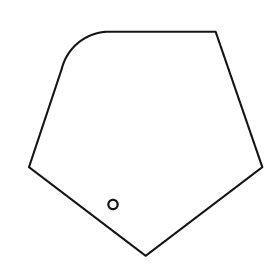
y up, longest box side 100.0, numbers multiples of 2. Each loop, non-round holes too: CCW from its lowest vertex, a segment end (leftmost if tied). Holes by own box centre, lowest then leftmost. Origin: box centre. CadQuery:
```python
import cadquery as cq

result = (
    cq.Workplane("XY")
    .moveTo(0.0, -48.0)
    .lineTo(50.0, -10.0)
    .lineTo(30.0, 48.0)
    .lineTo(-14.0, 48.0)
    .threePointArc((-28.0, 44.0), (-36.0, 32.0))
    .lineTo(-50.0, -10.0)
    .close()
    .moveTo(-14.0, -26.0)
    .circle(2.0)
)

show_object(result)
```